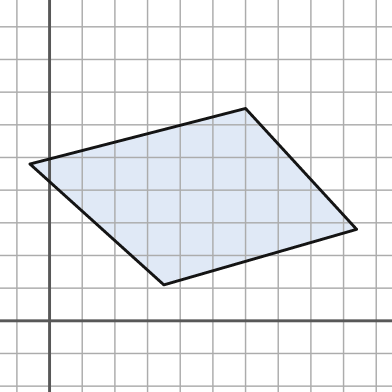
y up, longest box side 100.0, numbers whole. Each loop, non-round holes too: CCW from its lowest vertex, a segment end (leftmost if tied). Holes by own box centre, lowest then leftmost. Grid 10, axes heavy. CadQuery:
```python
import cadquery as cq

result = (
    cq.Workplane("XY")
    .moveTo(35.0, 11.0)
    .lineTo(94.0, 28.0)
    .lineTo(60.0, 65.0)
    .lineTo(-6.0, 48.0)
    .close()
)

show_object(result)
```